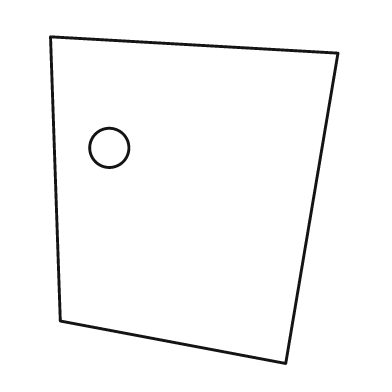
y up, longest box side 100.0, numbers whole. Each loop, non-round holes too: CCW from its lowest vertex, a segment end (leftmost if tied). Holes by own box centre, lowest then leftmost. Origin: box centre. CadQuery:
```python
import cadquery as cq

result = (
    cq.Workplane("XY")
    .moveTo(28.0, -50.0)
    .lineTo(44.0, 45.0)
    .lineTo(-44.0, 50.0)
    .lineTo(-41.0, -37.0)
    .close()
    .moveTo(-26.0, 16.0)
    .circle(6.0)
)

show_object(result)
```